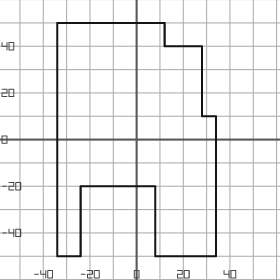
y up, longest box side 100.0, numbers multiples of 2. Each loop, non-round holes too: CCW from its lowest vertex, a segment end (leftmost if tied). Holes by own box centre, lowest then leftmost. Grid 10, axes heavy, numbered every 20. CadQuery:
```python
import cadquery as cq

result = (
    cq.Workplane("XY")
    .moveTo(-34.0, -50.0)
    .lineTo(-24.0, -50.0)
    .lineTo(-24.0, -20.0)
    .lineTo(8.0, -20.0)
    .lineTo(8.0, -50.0)
    .lineTo(34.0, -50.0)
    .lineTo(34.0, 10.0)
    .lineTo(28.0, 10.0)
    .lineTo(28.0, 40.0)
    .lineTo(12.0, 40.0)
    .lineTo(12.0, 50.0)
    .lineTo(-34.0, 50.0)
    .close()
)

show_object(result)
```